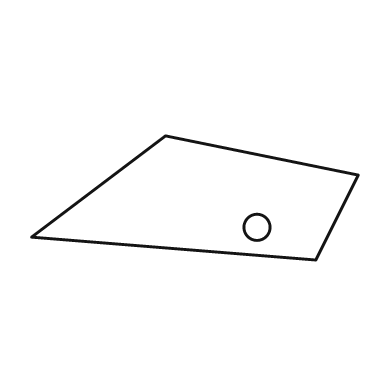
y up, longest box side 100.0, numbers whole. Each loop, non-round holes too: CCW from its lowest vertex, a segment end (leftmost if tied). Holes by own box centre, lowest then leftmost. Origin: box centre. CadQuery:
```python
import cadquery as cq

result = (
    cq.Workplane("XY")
    .moveTo(37.0, -19.0)
    .lineTo(50.0, 7.0)
    .lineTo(-9.0, 19.0)
    .lineTo(-50.0, -12.0)
    .close()
    .moveTo(19.0, -9.0)
    .circle(4.0)
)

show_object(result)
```